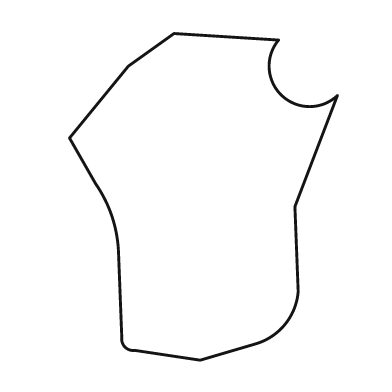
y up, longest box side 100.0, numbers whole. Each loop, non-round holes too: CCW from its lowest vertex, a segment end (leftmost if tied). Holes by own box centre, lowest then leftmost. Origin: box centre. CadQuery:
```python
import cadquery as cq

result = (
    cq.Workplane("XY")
    .moveTo(-1.0, -50.0)
    .lineTo(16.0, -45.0)
    .threePointArc((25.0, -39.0), (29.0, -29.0))
    .lineTo(28.0, -3.0)
    .lineTo(41.0, 31.0)
    .threePointArc((24.0, 31.0), (23.0, 48.0))
    .lineTo(-9.0, 50.0)
    .lineTo(-23.0, 40.0)
    .lineTo(-41.0, 18.0)
    .lineTo(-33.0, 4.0)
    .threePointArc((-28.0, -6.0), (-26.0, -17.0))
    .lineTo(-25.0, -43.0)
    .threePointArc((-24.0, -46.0), (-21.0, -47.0))
    .close()
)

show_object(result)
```